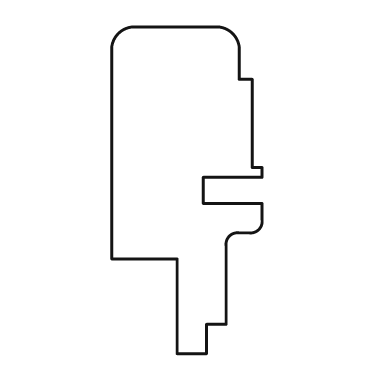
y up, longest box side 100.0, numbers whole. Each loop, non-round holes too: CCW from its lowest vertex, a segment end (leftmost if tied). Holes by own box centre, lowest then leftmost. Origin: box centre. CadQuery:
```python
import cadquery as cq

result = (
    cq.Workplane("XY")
    .moveTo(-3.0, -50.0)
    .lineTo(6.0, -50.0)
    .lineTo(6.0, -41.0)
    .lineTo(12.0, -41.0)
    .lineTo(12.0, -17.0)
    .threePointArc((13.0, -14.0), (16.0, -13.0))
    .lineTo(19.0, -13.0)
    .threePointArc((22.0, -12.0), (23.0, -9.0))
    .lineTo(23.0, -4.0)
    .lineTo(5.0, -4.0)
    .lineTo(5.0, 4.0)
    .lineTo(23.0, 4.0)
    .lineTo(23.0, 7.0)
    .lineTo(20.0, 7.0)
    .lineTo(20.0, 34.0)
    .lineTo(16.0, 34.0)
    .lineTo(16.0, 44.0)
    .threePointArc((14.0, 48.0), (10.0, 50.0))
    .lineTo(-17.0, 50.0)
    .threePointArc((-21.0, 48.0), (-23.0, 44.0))
    .lineTo(-23.0, -21.0)
    .lineTo(-3.0, -21.0)
    .close()
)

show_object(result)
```